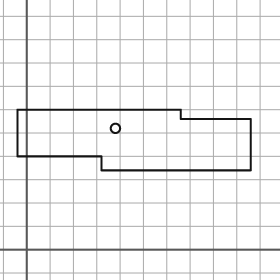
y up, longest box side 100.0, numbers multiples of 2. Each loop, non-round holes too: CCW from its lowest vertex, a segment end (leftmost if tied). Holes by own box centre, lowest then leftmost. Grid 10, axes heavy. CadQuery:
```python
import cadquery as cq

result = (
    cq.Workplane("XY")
    .moveTo(32.0, 34.0)
    .lineTo(96.0, 34.0)
    .lineTo(96.0, 56.0)
    .lineTo(66.0, 56.0)
    .lineTo(66.0, 60.0)
    .lineTo(-4.0, 60.0)
    .lineTo(-4.0, 40.0)
    .lineTo(32.0, 40.0)
    .close()
    .moveTo(38.0, 52.0)
    .circle(2.0)
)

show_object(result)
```